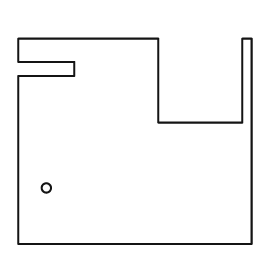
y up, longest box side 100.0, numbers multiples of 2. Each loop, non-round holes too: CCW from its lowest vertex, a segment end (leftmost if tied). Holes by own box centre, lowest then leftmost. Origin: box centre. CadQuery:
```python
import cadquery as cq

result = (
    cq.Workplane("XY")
    .moveTo(-50.0, -44.0)
    .lineTo(50.0, -44.0)
    .lineTo(50.0, 44.0)
    .lineTo(46.0, 44.0)
    .lineTo(46.0, 8.0)
    .lineTo(10.0, 8.0)
    .lineTo(10.0, 44.0)
    .lineTo(-50.0, 44.0)
    .lineTo(-50.0, 34.0)
    .lineTo(-26.0, 34.0)
    .lineTo(-26.0, 28.0)
    .lineTo(-50.0, 28.0)
    .close()
    .moveTo(-38.0, -20.0)
    .circle(2.0)
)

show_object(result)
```